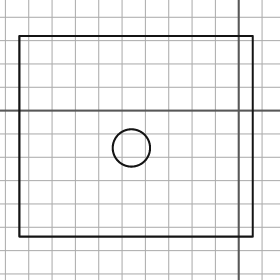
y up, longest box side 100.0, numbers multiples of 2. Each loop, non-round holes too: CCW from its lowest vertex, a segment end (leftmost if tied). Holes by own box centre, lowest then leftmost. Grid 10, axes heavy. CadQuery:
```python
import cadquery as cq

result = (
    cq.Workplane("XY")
    .moveTo(-94.0, -54.0)
    .lineTo(6.0, -54.0)
    .lineTo(6.0, 32.0)
    .lineTo(-94.0, 32.0)
    .close()
    .moveTo(-46.0, -16.0)
    .circle(8.0)
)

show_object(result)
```